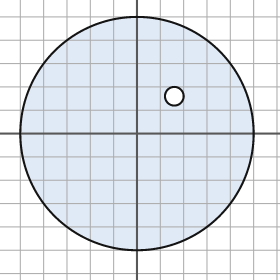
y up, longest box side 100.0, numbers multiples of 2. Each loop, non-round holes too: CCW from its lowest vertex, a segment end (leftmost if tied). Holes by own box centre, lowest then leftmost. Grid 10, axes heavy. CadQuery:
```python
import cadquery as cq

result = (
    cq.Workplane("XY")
    .moveTo(0.0, 0.0)
    .circle(50.0)
    .moveTo(16.0, 16.0)
    .circle(4.0)
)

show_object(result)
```